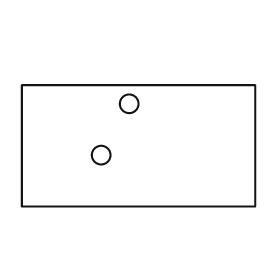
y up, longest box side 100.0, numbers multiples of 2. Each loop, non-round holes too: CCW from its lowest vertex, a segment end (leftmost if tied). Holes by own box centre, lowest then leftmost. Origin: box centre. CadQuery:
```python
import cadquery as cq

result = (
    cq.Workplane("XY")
    .moveTo(-50.0, -26.0)
    .lineTo(50.0, -26.0)
    .lineTo(50.0, 26.0)
    .lineTo(-50.0, 26.0)
    .close()
    .moveTo(-16.0, -4.0)
    .circle(4.0)
    .moveTo(-4.0, 18.0)
    .circle(4.0)
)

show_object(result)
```